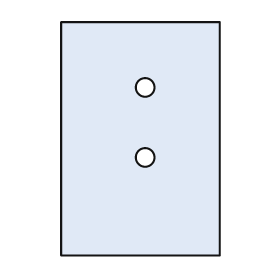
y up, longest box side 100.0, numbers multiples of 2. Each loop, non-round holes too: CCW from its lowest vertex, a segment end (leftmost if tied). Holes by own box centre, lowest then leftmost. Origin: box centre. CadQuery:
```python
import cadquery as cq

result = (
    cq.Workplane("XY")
    .moveTo(-34.0, -50.0)
    .lineTo(34.0, -50.0)
    .lineTo(34.0, 50.0)
    .lineTo(-34.0, 50.0)
    .close()
    .moveTo(2.0, -8.0)
    .circle(4.0)
    .moveTo(2.0, 22.0)
    .circle(4.0)
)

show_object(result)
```